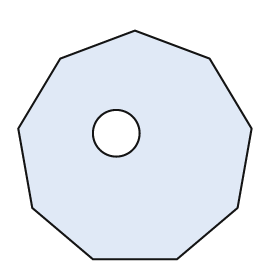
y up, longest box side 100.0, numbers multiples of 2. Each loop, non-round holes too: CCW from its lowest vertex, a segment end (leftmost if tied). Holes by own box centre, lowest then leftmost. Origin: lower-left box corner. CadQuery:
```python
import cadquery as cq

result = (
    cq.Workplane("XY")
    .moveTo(32.0, 0.0)
    .lineTo(68.0, 0.0)
    .lineTo(94.0, 22.0)
    .lineTo(100.0, 56.0)
    .lineTo(82.0, 86.0)
    .lineTo(50.0, 98.0)
    .lineTo(18.0, 86.0)
    .lineTo(0.0, 56.0)
    .lineTo(6.0, 22.0)
    .close()
    .moveTo(42.0, 54.0)
    .circle(10.0)
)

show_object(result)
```